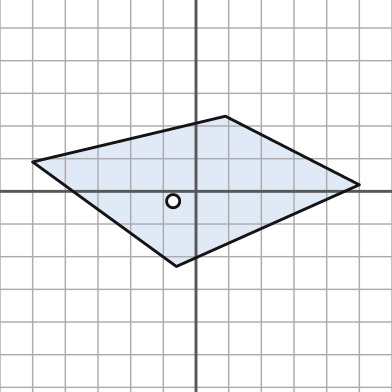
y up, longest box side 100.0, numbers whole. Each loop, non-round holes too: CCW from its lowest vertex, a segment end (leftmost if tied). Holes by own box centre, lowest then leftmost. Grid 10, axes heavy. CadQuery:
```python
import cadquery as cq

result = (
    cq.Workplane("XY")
    .moveTo(-6.0, -23.0)
    .lineTo(50.0, 2.0)
    .lineTo(9.0, 23.0)
    .lineTo(-50.0, 9.0)
    .close()
    .moveTo(-7.0, -3.0)
    .circle(2.0)
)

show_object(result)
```